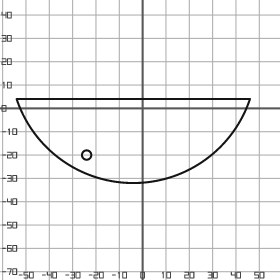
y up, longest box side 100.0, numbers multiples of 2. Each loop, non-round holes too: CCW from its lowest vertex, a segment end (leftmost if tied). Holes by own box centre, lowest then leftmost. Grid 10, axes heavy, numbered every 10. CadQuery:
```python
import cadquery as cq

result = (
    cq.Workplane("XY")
    .moveTo(-54.0, 4.0)
    .threePointArc((-4.0, -32.0), (46.0, 4.0))
    .close()
    .moveTo(-24.0, -20.0)
    .circle(2.0)
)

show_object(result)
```